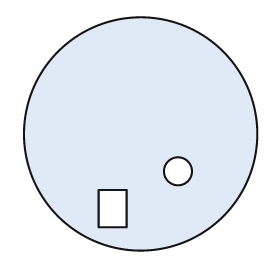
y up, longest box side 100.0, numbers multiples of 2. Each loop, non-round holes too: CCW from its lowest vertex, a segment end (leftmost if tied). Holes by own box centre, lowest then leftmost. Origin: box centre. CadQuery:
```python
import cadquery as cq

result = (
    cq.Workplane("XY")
    .moveTo(0.0, 0.0)
    .circle(50.0)
    .moveTo(-18.0, -40.0)
    .lineTo(-6.0, -40.0)
    .lineTo(-6.0, -24.0)
    .lineTo(-18.0, -24.0)
    .close()
    .moveTo(16.0, -16.0)
    .circle(6.0)
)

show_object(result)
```